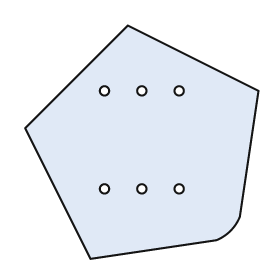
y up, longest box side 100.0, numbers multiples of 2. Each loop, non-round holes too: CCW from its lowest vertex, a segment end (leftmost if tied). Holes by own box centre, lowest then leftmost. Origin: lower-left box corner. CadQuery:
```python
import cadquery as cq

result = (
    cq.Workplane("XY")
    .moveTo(28.0, 0.0)
    .lineTo(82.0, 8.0)
    .threePointArc((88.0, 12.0), (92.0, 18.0))
    .lineTo(100.0, 72.0)
    .lineTo(44.0, 100.0)
    .lineTo(0.0, 56.0)
    .close()
    .moveTo(34.0, 30.0)
    .circle(2.0)
    .moveTo(50.0, 30.0)
    .circle(2.0)
    .moveTo(66.0, 30.0)
    .circle(2.0)
    .moveTo(34.0, 72.0)
    .circle(2.0)
    .moveTo(50.0, 72.0)
    .circle(2.0)
    .moveTo(66.0, 72.0)
    .circle(2.0)
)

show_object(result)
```